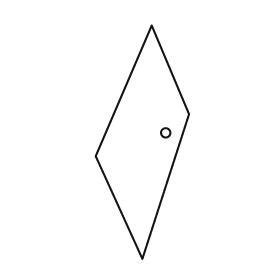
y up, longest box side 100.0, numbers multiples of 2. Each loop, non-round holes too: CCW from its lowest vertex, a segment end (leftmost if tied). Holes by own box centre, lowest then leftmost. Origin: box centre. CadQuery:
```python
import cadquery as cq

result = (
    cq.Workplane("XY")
    .moveTo(0.0, -50.0)
    .lineTo(20.0, 12.0)
    .lineTo(4.0, 50.0)
    .lineTo(-20.0, -6.0)
    .close()
    .moveTo(10.0, 4.0)
    .circle(2.0)
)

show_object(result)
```